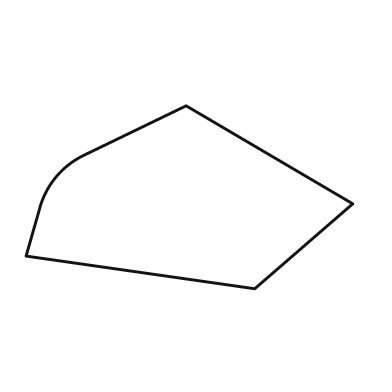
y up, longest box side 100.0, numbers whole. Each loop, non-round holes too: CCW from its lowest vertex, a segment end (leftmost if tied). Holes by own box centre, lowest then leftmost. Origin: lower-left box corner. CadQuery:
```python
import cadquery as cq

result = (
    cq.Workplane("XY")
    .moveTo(70.0, 0.0)
    .lineTo(100.0, 26.0)
    .lineTo(49.0, 56.0)
    .lineTo(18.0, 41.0)
    .threePointArc((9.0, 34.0), (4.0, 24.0))
    .lineTo(0.0, 10.0)
    .close()
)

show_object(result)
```